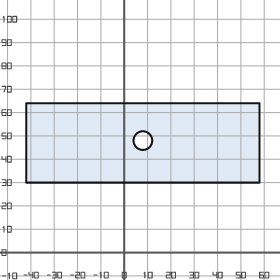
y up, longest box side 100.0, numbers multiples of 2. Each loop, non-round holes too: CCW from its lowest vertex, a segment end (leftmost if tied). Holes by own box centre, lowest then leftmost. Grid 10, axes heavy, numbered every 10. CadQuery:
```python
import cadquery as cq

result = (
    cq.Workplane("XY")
    .moveTo(-42.0, 30.0)
    .lineTo(58.0, 30.0)
    .lineTo(58.0, 64.0)
    .lineTo(-42.0, 64.0)
    .close()
    .moveTo(8.0, 48.0)
    .circle(4.0)
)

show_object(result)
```